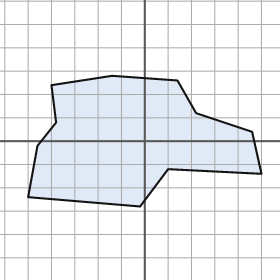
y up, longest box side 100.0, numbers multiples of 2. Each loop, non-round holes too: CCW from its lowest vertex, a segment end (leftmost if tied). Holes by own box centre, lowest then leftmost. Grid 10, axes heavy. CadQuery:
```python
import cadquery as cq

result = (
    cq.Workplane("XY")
    .moveTo(-2.0, -28.0)
    .lineTo(10.0, -12.0)
    .lineTo(50.0, -14.0)
    .lineTo(46.0, 4.0)
    .lineTo(22.0, 12.0)
    .lineTo(14.0, 26.0)
    .lineTo(-14.0, 28.0)
    .lineTo(-40.0, 24.0)
    .lineTo(-38.0, 8.0)
    .lineTo(-46.0, -2.0)
    .lineTo(-50.0, -24.0)
    .close()
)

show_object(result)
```